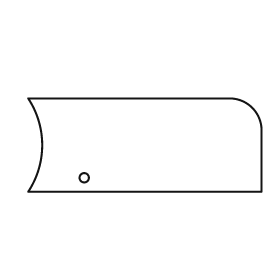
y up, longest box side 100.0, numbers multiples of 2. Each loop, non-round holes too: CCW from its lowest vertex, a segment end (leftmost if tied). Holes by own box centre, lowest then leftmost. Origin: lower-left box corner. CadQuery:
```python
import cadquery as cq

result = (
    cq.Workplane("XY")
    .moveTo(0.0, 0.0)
    .lineTo(100.0, 0.0)
    .lineTo(100.0, 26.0)
    .threePointArc((96.0, 36.0), (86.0, 40.0))
    .lineTo(0.0, 40.0)
    .threePointArc((6.0, 20.0), (0.0, 0.0))
    .close()
    .moveTo(24.0, 6.0)
    .circle(2.0)
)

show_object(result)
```